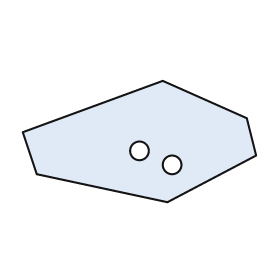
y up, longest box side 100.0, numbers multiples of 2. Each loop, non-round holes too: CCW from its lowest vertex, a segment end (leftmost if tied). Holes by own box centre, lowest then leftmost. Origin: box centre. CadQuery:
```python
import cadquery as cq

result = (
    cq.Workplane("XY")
    .moveTo(12.0, -26.0)
    .lineTo(50.0, -6.0)
    .lineTo(46.0, 10.0)
    .lineTo(10.0, 26.0)
    .lineTo(-50.0, 4.0)
    .lineTo(-44.0, -14.0)
    .close()
    .moveTo(14.0, -10.0)
    .circle(4.0)
    .moveTo(0.0, -4.0)
    .circle(4.0)
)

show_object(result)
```